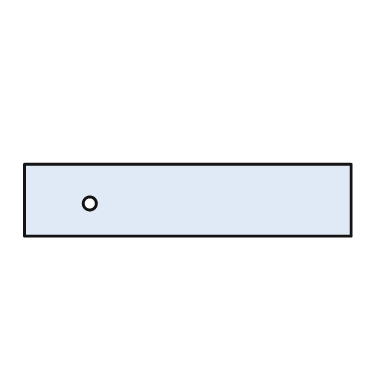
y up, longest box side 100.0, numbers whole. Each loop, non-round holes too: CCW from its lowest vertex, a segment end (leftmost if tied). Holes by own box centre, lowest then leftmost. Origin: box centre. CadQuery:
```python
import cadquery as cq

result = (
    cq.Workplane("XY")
    .moveTo(-50.0, -11.0)
    .lineTo(50.0, -11.0)
    .lineTo(50.0, 11.0)
    .lineTo(-50.0, 11.0)
    .close()
    .moveTo(-30.0, -1.0)
    .circle(2.0)
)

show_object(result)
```